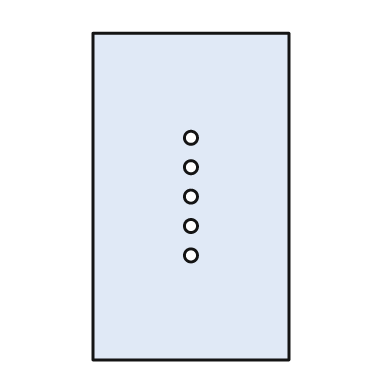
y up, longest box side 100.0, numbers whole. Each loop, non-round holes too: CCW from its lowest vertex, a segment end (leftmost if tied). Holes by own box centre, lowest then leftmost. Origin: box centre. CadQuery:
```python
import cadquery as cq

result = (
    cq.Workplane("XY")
    .moveTo(-30.0, -50.0)
    .lineTo(30.0, -50.0)
    .lineTo(30.0, 50.0)
    .lineTo(-30.0, 50.0)
    .close()
    .moveTo(0.0, -18.0)
    .circle(2.0)
    .moveTo(0.0, -9.0)
    .circle(2.0)
    .moveTo(0.0, 0.0)
    .circle(2.0)
    .moveTo(0.0, 9.0)
    .circle(2.0)
    .moveTo(0.0, 18.0)
    .circle(2.0)
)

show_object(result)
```